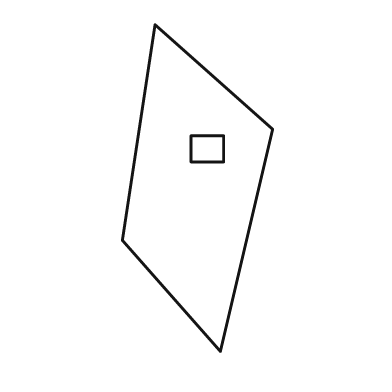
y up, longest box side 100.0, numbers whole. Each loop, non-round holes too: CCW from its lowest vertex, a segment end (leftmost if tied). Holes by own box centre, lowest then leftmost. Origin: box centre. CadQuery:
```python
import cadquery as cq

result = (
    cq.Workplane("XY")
    .moveTo(7.0, -50.0)
    .lineTo(23.0, 18.0)
    .lineTo(-13.0, 50.0)
    .lineTo(-23.0, -16.0)
    .close()
    .moveTo(-2.0, 8.0)
    .lineTo(8.0, 8.0)
    .lineTo(8.0, 16.0)
    .lineTo(-2.0, 16.0)
    .close()
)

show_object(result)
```